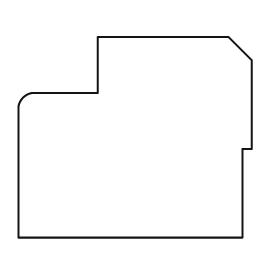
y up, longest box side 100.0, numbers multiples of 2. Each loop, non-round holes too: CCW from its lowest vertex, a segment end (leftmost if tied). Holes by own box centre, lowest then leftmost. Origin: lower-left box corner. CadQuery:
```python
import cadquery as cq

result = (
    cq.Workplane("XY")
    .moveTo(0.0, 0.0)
    .lineTo(96.0, 0.0)
    .lineTo(96.0, 38.0)
    .lineTo(100.0, 38.0)
    .lineTo(100.0, 76.0)
    .lineTo(90.0, 86.0)
    .lineTo(34.0, 86.0)
    .lineTo(34.0, 62.0)
    .lineTo(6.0, 62.0)
    .threePointArc((2.0, 60.0), (0.0, 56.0))
    .close()
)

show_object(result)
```